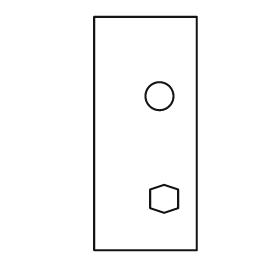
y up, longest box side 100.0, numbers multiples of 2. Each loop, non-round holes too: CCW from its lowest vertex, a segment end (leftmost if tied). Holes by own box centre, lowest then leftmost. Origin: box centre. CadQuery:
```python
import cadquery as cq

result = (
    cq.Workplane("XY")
    .moveTo(-22.0, -50.0)
    .lineTo(22.0, -50.0)
    .lineTo(22.0, 50.0)
    .lineTo(-22.0, 50.0)
    .close()
    .moveTo(8.0, -34.0)
    .lineTo(14.0, -32.0)
    .lineTo(14.0, -24.0)
    .lineTo(8.0, -22.0)
    .lineTo(2.0, -24.0)
    .lineTo(2.0, -32.0)
    .close()
    .moveTo(6.0, 16.0)
    .circle(6.0)
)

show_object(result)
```